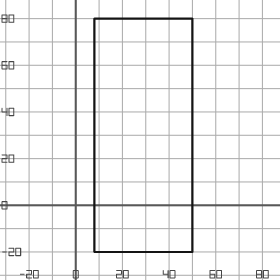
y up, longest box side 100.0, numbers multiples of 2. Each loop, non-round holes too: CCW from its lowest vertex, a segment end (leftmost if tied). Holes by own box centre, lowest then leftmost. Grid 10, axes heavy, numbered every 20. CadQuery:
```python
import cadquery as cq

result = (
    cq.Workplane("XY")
    .moveTo(8.0, -20.0)
    .lineTo(50.0, -20.0)
    .lineTo(50.0, 80.0)
    .lineTo(8.0, 80.0)
    .close()
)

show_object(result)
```